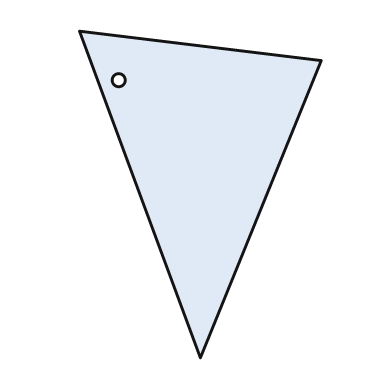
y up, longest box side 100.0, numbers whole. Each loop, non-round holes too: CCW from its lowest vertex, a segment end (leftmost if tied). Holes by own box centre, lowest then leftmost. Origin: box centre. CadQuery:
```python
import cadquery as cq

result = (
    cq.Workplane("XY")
    .moveTo(0.0, -50.0)
    .lineTo(37.0, 41.0)
    .lineTo(-37.0, 50.0)
    .close()
    .moveTo(-25.0, 35.0)
    .circle(2.0)
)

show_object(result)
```